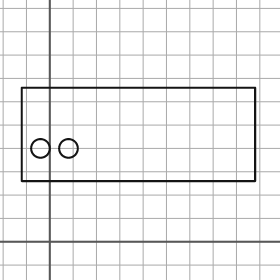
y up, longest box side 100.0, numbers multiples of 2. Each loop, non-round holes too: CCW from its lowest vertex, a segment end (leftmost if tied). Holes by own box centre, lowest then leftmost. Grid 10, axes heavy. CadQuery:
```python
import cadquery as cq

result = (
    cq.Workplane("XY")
    .moveTo(-12.0, 26.0)
    .lineTo(88.0, 26.0)
    .lineTo(88.0, 66.0)
    .lineTo(-12.0, 66.0)
    .close()
    .moveTo(-4.0, 40.0)
    .circle(4.0)
    .moveTo(8.0, 40.0)
    .circle(4.0)
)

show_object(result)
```